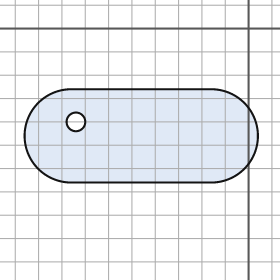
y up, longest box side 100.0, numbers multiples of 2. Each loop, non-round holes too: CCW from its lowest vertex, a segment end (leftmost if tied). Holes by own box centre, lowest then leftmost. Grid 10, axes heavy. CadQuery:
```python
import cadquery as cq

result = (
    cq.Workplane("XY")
    .moveTo(-76.0, -66.0)
    .lineTo(-16.0, -66.0)
    .threePointArc((4.0, -46.0), (-16.0, -26.0))
    .lineTo(-76.0, -26.0)
    .threePointArc((-96.0, -46.0), (-76.0, -66.0))
    .close()
    .moveTo(-74.0, -40.0)
    .circle(4.0)
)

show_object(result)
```